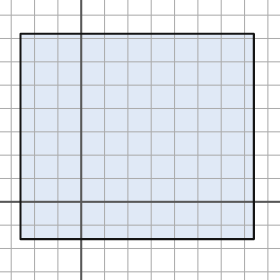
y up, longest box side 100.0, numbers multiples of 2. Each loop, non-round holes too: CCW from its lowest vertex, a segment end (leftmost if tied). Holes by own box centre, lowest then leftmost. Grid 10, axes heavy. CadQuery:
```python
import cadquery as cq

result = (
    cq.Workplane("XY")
    .moveTo(-26.0, -16.0)
    .lineTo(74.0, -16.0)
    .lineTo(74.0, 72.0)
    .lineTo(-26.0, 72.0)
    .close()
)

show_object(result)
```